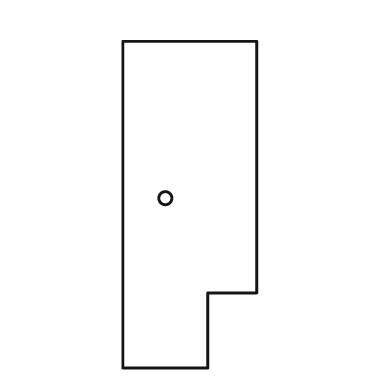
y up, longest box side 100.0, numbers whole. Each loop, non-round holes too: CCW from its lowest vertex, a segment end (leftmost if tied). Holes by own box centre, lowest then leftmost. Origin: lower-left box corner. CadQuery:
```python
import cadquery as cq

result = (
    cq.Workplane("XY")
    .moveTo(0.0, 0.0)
    .lineTo(26.0, 0.0)
    .lineTo(26.0, 23.0)
    .lineTo(41.0, 23.0)
    .lineTo(41.0, 100.0)
    .lineTo(0.0, 100.0)
    .close()
    .moveTo(13.0, 52.0)
    .circle(2.0)
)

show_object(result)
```